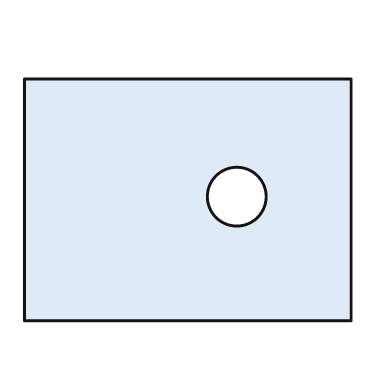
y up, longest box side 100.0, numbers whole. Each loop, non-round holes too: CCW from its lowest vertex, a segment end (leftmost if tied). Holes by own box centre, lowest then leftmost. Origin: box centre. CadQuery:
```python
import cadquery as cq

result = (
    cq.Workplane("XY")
    .moveTo(-50.0, -37.0)
    .lineTo(50.0, -37.0)
    .lineTo(50.0, 37.0)
    .lineTo(-50.0, 37.0)
    .close()
    .moveTo(15.0, 1.0)
    .circle(9.0)
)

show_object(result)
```